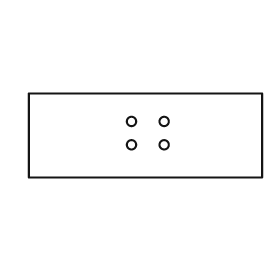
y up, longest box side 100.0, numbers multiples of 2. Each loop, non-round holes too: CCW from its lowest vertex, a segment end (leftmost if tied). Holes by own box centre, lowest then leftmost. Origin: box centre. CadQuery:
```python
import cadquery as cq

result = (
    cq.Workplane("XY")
    .moveTo(-50.0, -18.0)
    .lineTo(50.0, -18.0)
    .lineTo(50.0, 18.0)
    .lineTo(-50.0, 18.0)
    .close()
    .moveTo(-6.0, -4.0)
    .circle(2.0)
    .moveTo(8.0, -4.0)
    .circle(2.0)
    .moveTo(-6.0, 6.0)
    .circle(2.0)
    .moveTo(8.0, 6.0)
    .circle(2.0)
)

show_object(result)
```